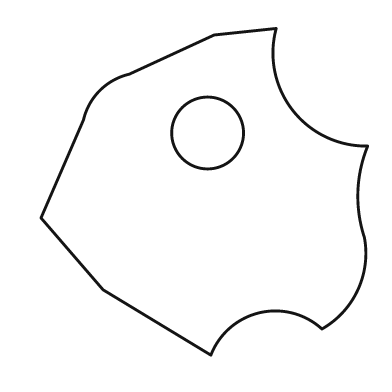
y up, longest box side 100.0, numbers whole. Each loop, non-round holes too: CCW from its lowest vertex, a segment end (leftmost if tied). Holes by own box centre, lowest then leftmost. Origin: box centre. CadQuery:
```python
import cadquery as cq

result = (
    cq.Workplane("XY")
    .moveTo(2.0, -50.0)
    .threePointArc((17.0, -37.0), (36.0, -42.0))
    .threePointArc((47.0, -30.0), (49.0, -14.0))
    .threePointArc((47.0, 0.0), (50.0, 14.0))
    .threePointArc((27.0, 25.0), (22.0, 50.0))
    .lineTo(3.0, 48.0)
    .lineTo(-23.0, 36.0)
    .threePointArc((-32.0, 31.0), (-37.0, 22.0))
    .lineTo(-50.0, -8.0)
    .lineTo(-31.0, -30.0)
    .close()
    .moveTo(1.0, 18.0)
    .circle(11.0)
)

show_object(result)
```